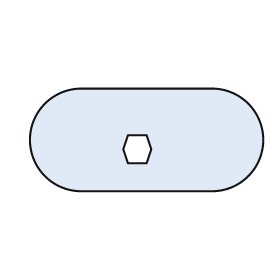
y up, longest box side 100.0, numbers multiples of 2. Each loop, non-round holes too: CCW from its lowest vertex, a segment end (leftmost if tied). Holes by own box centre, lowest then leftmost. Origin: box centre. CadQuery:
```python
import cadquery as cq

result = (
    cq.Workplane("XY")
    .moveTo(-28.0, -22.0)
    .lineTo(28.0, -22.0)
    .threePointArc((50.0, 0.0), (28.0, 22.0))
    .lineTo(-28.0, 22.0)
    .threePointArc((-50.0, 0.0), (-28.0, -22.0))
    .close()
    .moveTo(-8.0, -10.0)
    .lineTo(0.0, -10.0)
    .lineTo(2.0, -4.0)
    .lineTo(0.0, 2.0)
    .lineTo(-8.0, 2.0)
    .lineTo(-10.0, -4.0)
    .close()
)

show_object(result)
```